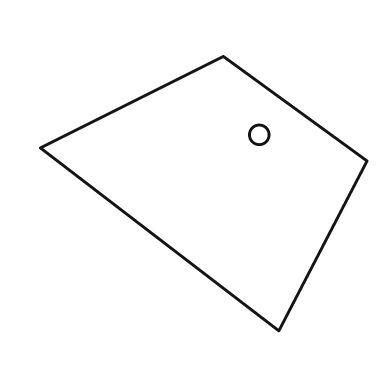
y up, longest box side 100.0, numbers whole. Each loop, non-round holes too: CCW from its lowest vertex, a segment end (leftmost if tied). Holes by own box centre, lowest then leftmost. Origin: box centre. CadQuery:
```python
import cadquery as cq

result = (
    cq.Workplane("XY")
    .moveTo(23.0, -42.0)
    .lineTo(50.0, 10.0)
    .lineTo(6.0, 42.0)
    .lineTo(-50.0, 14.0)
    .close()
    .moveTo(17.0, 18.0)
    .circle(3.0)
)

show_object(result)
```